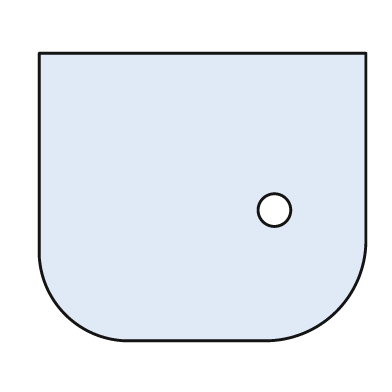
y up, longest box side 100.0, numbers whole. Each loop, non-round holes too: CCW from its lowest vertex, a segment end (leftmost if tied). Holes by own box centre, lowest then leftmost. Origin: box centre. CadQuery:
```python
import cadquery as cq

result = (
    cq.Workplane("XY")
    .moveTo(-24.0, -44.0)
    .lineTo(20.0, -44.0)
    .threePointArc((41.0, -35.0), (50.0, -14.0))
    .lineTo(50.0, 44.0)
    .lineTo(-50.0, 44.0)
    .lineTo(-50.0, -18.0)
    .threePointArc((-42.0, -36.0), (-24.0, -44.0))
    .close()
    .moveTo(22.0, -4.0)
    .circle(5.0)
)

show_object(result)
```